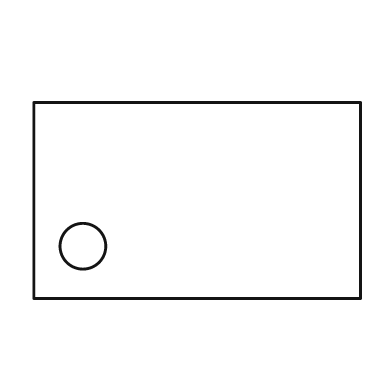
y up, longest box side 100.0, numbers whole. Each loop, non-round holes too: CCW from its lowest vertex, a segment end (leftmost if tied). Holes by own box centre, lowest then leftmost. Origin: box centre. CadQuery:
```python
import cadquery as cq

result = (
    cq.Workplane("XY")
    .moveTo(-50.0, -30.0)
    .lineTo(50.0, -30.0)
    .lineTo(50.0, 30.0)
    .lineTo(-50.0, 30.0)
    .close()
    .moveTo(-35.0, -14.0)
    .circle(7.0)
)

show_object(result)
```